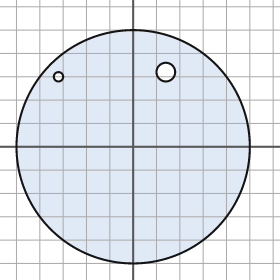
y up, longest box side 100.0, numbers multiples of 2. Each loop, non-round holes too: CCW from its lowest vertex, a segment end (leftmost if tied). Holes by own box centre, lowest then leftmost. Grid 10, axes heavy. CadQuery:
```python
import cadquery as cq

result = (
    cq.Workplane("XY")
    .moveTo(0.0, 0.0)
    .circle(50.0)
    .moveTo(-32.0, 30.0)
    .circle(2.0)
    .moveTo(14.0, 32.0)
    .circle(4.0)
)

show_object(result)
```